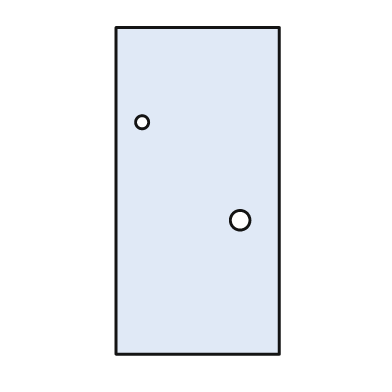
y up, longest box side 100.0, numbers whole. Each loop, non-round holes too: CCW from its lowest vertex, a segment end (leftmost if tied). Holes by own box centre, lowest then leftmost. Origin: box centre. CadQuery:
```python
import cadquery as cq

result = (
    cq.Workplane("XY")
    .moveTo(-25.0, -50.0)
    .lineTo(25.0, -50.0)
    .lineTo(25.0, 50.0)
    .lineTo(-25.0, 50.0)
    .close()
    .moveTo(13.0, -9.0)
    .circle(3.0)
    .moveTo(-17.0, 21.0)
    .circle(2.0)
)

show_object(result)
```